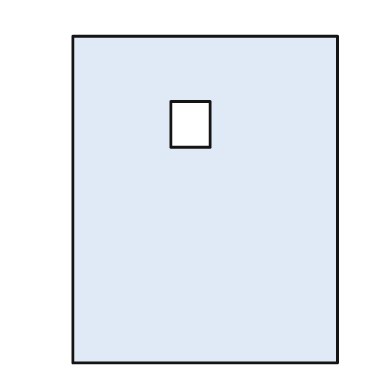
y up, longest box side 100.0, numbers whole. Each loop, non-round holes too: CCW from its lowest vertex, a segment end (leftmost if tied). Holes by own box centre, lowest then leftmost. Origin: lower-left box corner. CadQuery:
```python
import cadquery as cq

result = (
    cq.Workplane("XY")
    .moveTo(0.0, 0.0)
    .lineTo(81.0, 0.0)
    .lineTo(81.0, 100.0)
    .lineTo(0.0, 100.0)
    .close()
    .moveTo(30.0, 66.0)
    .lineTo(42.0, 66.0)
    .lineTo(42.0, 80.0)
    .lineTo(30.0, 80.0)
    .close()
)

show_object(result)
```